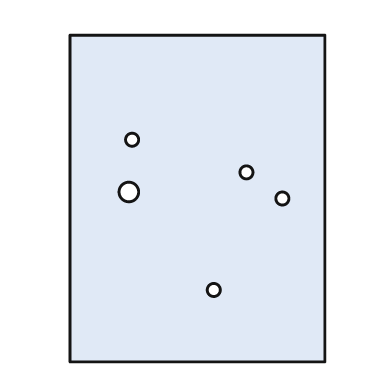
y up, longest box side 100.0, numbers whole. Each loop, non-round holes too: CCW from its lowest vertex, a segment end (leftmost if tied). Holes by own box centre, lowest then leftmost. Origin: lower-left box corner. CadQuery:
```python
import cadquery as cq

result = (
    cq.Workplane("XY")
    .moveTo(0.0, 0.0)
    .lineTo(78.0, 0.0)
    .lineTo(78.0, 100.0)
    .lineTo(0.0, 100.0)
    .close()
    .moveTo(44.0, 22.0)
    .circle(2.0)
    .moveTo(65.0, 50.0)
    .circle(2.0)
    .moveTo(18.0, 52.0)
    .circle(3.0)
    .moveTo(54.0, 58.0)
    .circle(2.0)
    .moveTo(19.0, 68.0)
    .circle(2.0)
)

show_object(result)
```